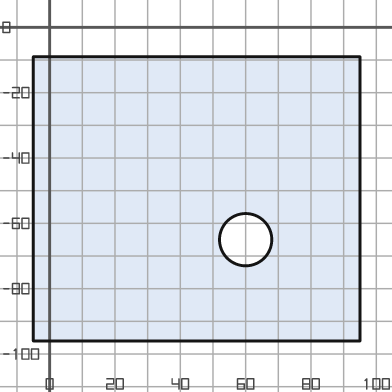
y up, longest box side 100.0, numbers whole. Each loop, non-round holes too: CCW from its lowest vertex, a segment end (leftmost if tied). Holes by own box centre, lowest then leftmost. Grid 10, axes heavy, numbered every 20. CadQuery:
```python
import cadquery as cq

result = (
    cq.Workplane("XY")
    .moveTo(-5.0, -96.0)
    .lineTo(95.0, -96.0)
    .lineTo(95.0, -9.0)
    .lineTo(-5.0, -9.0)
    .close()
    .moveTo(60.0, -65.0)
    .circle(8.0)
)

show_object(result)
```